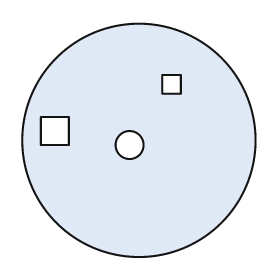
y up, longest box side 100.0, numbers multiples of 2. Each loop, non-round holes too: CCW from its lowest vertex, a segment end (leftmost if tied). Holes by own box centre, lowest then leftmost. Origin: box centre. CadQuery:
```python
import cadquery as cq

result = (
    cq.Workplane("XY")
    .moveTo(0.0, 0.0)
    .circle(50.0)
    .moveTo(-4.0, -2.0)
    .circle(6.0)
    .moveTo(-42.0, -2.0)
    .lineTo(-30.0, -2.0)
    .lineTo(-30.0, 10.0)
    .lineTo(-42.0, 10.0)
    .close()
    .moveTo(10.0, 20.0)
    .lineTo(18.0, 20.0)
    .lineTo(18.0, 28.0)
    .lineTo(10.0, 28.0)
    .close()
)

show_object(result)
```